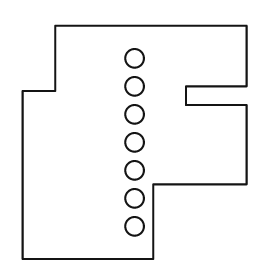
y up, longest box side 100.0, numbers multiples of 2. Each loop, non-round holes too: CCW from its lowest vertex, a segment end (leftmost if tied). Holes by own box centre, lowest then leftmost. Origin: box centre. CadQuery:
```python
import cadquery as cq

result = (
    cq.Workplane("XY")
    .moveTo(-48.0, -50.0)
    .lineTo(8.0, -50.0)
    .lineTo(8.0, -18.0)
    .lineTo(48.0, -18.0)
    .lineTo(48.0, 16.0)
    .lineTo(22.0, 16.0)
    .lineTo(22.0, 24.0)
    .lineTo(48.0, 24.0)
    .lineTo(48.0, 50.0)
    .lineTo(-34.0, 50.0)
    .lineTo(-34.0, 22.0)
    .lineTo(-48.0, 22.0)
    .close()
    .moveTo(0.0, -36.0)
    .circle(4.0)
    .moveTo(0.0, -24.0)
    .circle(4.0)
    .moveTo(0.0, -12.0)
    .circle(4.0)
    .moveTo(0.0, 0.0)
    .circle(4.0)
    .moveTo(0.0, 12.0)
    .circle(4.0)
    .moveTo(0.0, 24.0)
    .circle(4.0)
    .moveTo(0.0, 36.0)
    .circle(4.0)
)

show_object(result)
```